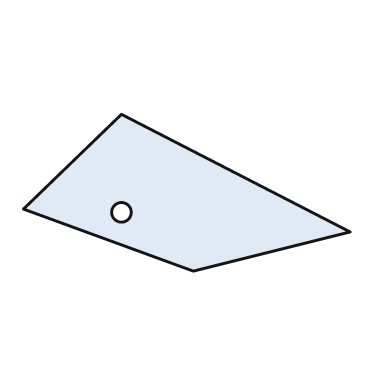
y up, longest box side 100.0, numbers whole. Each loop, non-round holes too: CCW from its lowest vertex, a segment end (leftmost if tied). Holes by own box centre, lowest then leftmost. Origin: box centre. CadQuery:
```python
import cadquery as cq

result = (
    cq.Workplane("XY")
    .moveTo(2.0, -24.0)
    .lineTo(50.0, -12.0)
    .lineTo(-20.0, 24.0)
    .lineTo(-50.0, -5.0)
    .close()
    .moveTo(-20.0, -6.0)
    .circle(3.0)
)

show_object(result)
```